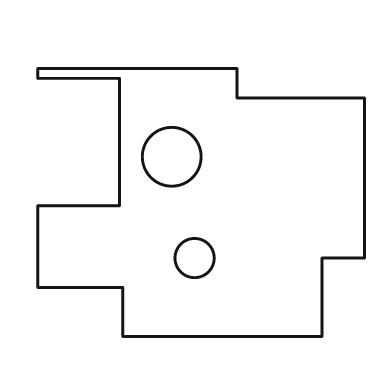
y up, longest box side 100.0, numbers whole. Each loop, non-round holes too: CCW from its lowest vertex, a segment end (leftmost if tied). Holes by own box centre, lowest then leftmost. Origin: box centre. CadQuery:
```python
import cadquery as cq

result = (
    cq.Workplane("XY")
    .moveTo(-24.0, -41.0)
    .lineTo(37.0, -41.0)
    .lineTo(37.0, -17.0)
    .lineTo(50.0, -17.0)
    .lineTo(50.0, 32.0)
    .lineTo(11.0, 32.0)
    .lineTo(11.0, 41.0)
    .lineTo(-50.0, 41.0)
    .lineTo(-50.0, 38.0)
    .lineTo(-25.0, 38.0)
    .lineTo(-25.0, -1.0)
    .lineTo(-50.0, -1.0)
    .lineTo(-50.0, -26.0)
    .lineTo(-24.0, -26.0)
    .close()
    .moveTo(-2.0, -17.0)
    .circle(6.0)
    .moveTo(-9.0, 14.0)
    .circle(9.0)
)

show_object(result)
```